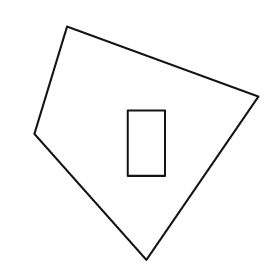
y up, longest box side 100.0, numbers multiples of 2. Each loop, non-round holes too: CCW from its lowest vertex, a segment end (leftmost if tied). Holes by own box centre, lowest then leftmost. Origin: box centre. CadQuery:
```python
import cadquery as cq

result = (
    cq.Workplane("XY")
    .moveTo(0.0, -50.0)
    .lineTo(48.0, 20.0)
    .lineTo(-34.0, 50.0)
    .lineTo(-48.0, 4.0)
    .close()
    .moveTo(-8.0, -14.0)
    .lineTo(8.0, -14.0)
    .lineTo(8.0, 14.0)
    .lineTo(-8.0, 14.0)
    .close()
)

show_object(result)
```